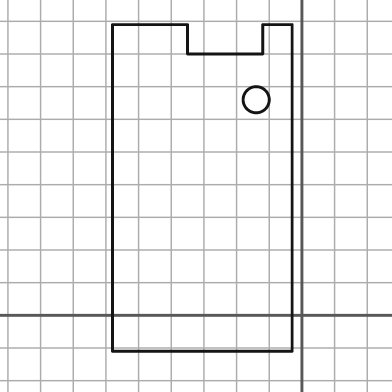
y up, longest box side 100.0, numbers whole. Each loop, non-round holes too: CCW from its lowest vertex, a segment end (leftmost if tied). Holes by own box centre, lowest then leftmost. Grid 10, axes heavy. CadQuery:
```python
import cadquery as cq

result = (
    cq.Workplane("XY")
    .moveTo(-58.0, -11.0)
    .lineTo(-3.0, -11.0)
    .lineTo(-3.0, 89.0)
    .lineTo(-12.0, 89.0)
    .lineTo(-12.0, 80.0)
    .lineTo(-35.0, 80.0)
    .lineTo(-35.0, 89.0)
    .lineTo(-58.0, 89.0)
    .close()
    .moveTo(-14.0, 66.0)
    .circle(4.0)
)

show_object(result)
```